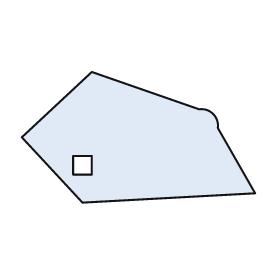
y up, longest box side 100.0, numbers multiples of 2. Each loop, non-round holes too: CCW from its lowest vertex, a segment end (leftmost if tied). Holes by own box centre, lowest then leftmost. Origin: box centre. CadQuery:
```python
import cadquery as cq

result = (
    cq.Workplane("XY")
    .moveTo(-24.0, -28.0)
    .lineTo(50.0, -24.0)
    .lineTo(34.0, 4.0)
    .threePointArc((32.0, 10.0), (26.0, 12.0))
    .lineTo(-20.0, 28.0)
    .lineTo(-50.0, 0.0)
    .close()
    .moveTo(-28.0, -16.0)
    .lineTo(-20.0, -16.0)
    .lineTo(-20.0, -8.0)
    .lineTo(-28.0, -8.0)
    .close()
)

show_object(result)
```